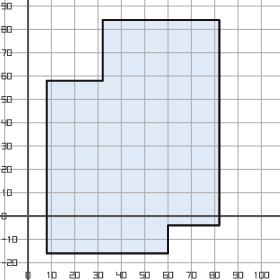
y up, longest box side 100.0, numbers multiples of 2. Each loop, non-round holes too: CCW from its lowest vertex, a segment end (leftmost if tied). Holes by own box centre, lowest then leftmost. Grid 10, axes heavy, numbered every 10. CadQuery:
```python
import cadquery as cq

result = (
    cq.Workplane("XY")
    .moveTo(8.0, -16.0)
    .lineTo(60.0, -16.0)
    .lineTo(60.0, -4.0)
    .lineTo(82.0, -4.0)
    .lineTo(82.0, 84.0)
    .lineTo(32.0, 84.0)
    .lineTo(32.0, 58.0)
    .lineTo(8.0, 58.0)
    .close()
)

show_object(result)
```